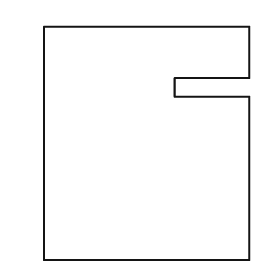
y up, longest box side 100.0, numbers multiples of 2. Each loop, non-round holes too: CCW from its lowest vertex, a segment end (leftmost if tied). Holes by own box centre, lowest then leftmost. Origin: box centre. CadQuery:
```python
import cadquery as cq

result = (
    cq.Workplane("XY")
    .moveTo(-44.0, -50.0)
    .lineTo(44.0, -50.0)
    .lineTo(44.0, 20.0)
    .lineTo(12.0, 20.0)
    .lineTo(12.0, 28.0)
    .lineTo(44.0, 28.0)
    .lineTo(44.0, 50.0)
    .lineTo(-44.0, 50.0)
    .close()
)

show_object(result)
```